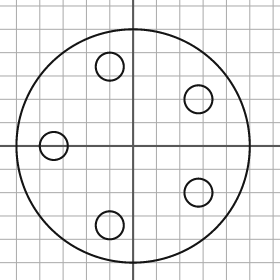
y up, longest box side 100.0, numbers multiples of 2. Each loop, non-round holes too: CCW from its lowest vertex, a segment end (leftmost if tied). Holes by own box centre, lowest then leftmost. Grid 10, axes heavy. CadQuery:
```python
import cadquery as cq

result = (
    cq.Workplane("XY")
    .moveTo(0.0, 0.0)
    .circle(50.0)
    .moveTo(-10.0, -34.0)
    .circle(6.0)
    .moveTo(28.0, -20.0)
    .circle(6.0)
    .moveTo(-34.0, 0.0)
    .circle(6.0)
    .moveTo(28.0, 20.0)
    .circle(6.0)
    .moveTo(-10.0, 34.0)
    .circle(6.0)
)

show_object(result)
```